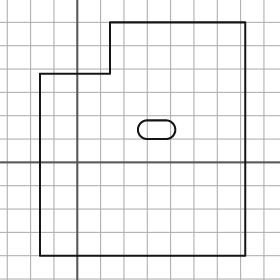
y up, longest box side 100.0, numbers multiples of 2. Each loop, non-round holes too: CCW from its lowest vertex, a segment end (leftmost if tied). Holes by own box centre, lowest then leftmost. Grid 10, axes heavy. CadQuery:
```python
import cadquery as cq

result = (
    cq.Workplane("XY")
    .moveTo(-16.0, -40.0)
    .lineTo(72.0, -40.0)
    .lineTo(72.0, 60.0)
    .lineTo(14.0, 60.0)
    .lineTo(14.0, 38.0)
    .lineTo(-16.0, 38.0)
    .close()
    .moveTo(30.0, 10.0)
    .lineTo(38.0, 10.0)
    .threePointArc((42.0, 14.0), (38.0, 18.0))
    .lineTo(30.0, 18.0)
    .threePointArc((26.0, 14.0), (30.0, 10.0))
    .close()
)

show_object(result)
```